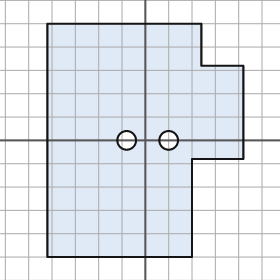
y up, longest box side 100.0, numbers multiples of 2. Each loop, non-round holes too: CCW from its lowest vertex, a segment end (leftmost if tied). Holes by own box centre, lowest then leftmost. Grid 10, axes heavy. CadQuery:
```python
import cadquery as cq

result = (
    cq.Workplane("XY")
    .moveTo(-42.0, -50.0)
    .lineTo(20.0, -50.0)
    .lineTo(20.0, -8.0)
    .lineTo(42.0, -8.0)
    .lineTo(42.0, 32.0)
    .lineTo(24.0, 32.0)
    .lineTo(24.0, 50.0)
    .lineTo(-42.0, 50.0)
    .close()
    .moveTo(-8.0, 0.0)
    .circle(4.0)
    .moveTo(10.0, 0.0)
    .circle(4.0)
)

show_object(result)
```